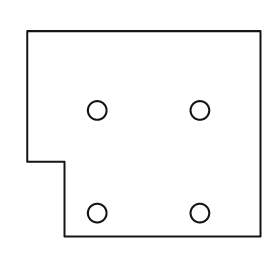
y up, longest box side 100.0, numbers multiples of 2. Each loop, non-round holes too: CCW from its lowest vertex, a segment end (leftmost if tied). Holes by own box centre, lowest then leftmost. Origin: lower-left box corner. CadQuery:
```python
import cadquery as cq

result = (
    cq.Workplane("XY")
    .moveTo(16.0, 0.0)
    .lineTo(100.0, 0.0)
    .lineTo(100.0, 88.0)
    .lineTo(0.0, 88.0)
    .lineTo(0.0, 32.0)
    .lineTo(16.0, 32.0)
    .close()
    .moveTo(30.0, 10.0)
    .circle(4.0)
    .moveTo(74.0, 10.0)
    .circle(4.0)
    .moveTo(30.0, 54.0)
    .circle(4.0)
    .moveTo(74.0, 54.0)
    .circle(4.0)
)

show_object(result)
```